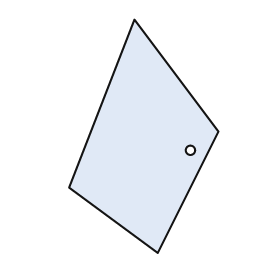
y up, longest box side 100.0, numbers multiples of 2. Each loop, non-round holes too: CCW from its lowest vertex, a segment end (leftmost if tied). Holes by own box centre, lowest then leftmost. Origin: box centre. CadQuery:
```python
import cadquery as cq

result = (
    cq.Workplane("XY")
    .moveTo(6.0, -50.0)
    .lineTo(32.0, 2.0)
    .lineTo(-4.0, 50.0)
    .lineTo(-32.0, -22.0)
    .close()
    .moveTo(20.0, -6.0)
    .circle(2.0)
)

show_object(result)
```